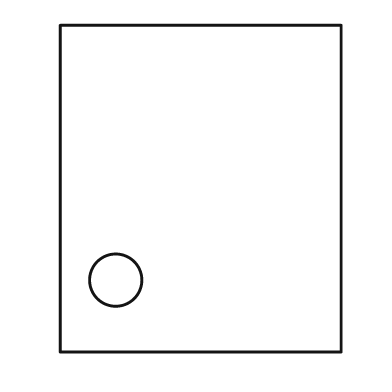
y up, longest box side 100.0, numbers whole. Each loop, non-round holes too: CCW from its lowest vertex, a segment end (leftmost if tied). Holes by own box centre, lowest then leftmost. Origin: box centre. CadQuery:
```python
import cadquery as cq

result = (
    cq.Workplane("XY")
    .moveTo(-43.0, -50.0)
    .lineTo(43.0, -50.0)
    .lineTo(43.0, 50.0)
    .lineTo(-43.0, 50.0)
    .close()
    .moveTo(-26.0, -28.0)
    .circle(8.0)
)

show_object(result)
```